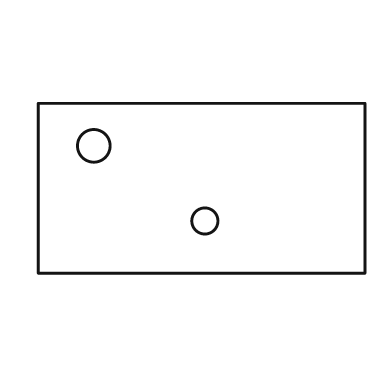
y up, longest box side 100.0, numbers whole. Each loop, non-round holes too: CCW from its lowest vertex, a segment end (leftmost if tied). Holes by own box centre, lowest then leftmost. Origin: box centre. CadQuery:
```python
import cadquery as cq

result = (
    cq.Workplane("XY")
    .moveTo(-50.0, -26.0)
    .lineTo(50.0, -26.0)
    .lineTo(50.0, 26.0)
    .lineTo(-50.0, 26.0)
    .close()
    .moveTo(1.0, -10.0)
    .circle(4.0)
    .moveTo(-33.0, 13.0)
    .circle(5.0)
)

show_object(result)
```